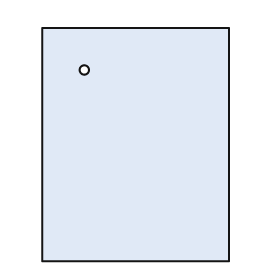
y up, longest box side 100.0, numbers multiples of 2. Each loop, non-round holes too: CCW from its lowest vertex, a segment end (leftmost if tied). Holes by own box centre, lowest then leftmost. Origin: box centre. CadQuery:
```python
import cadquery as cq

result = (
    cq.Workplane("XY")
    .moveTo(-40.0, -50.0)
    .lineTo(40.0, -50.0)
    .lineTo(40.0, 50.0)
    .lineTo(-40.0, 50.0)
    .close()
    .moveTo(-22.0, 32.0)
    .circle(2.0)
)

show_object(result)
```